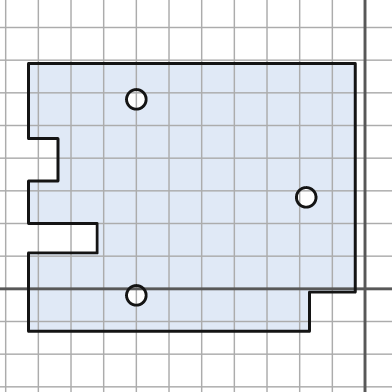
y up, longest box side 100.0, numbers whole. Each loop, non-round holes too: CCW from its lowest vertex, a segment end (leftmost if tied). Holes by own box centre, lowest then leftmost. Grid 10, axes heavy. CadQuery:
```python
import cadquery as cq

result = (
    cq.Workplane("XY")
    .moveTo(-103.0, -13.0)
    .lineTo(-17.0, -13.0)
    .lineTo(-17.0, -1.0)
    .lineTo(-3.0, -1.0)
    .lineTo(-3.0, 69.0)
    .lineTo(-103.0, 69.0)
    .lineTo(-103.0, 46.0)
    .lineTo(-94.0, 46.0)
    .lineTo(-94.0, 33.0)
    .lineTo(-103.0, 33.0)
    .lineTo(-103.0, 20.0)
    .lineTo(-82.0, 20.0)
    .lineTo(-82.0, 11.0)
    .lineTo(-103.0, 11.0)
    .close()
    .moveTo(-70.0, -2.0)
    .circle(3.0)
    .moveTo(-18.0, 28.0)
    .circle(3.0)
    .moveTo(-70.0, 58.0)
    .circle(3.0)
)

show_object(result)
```